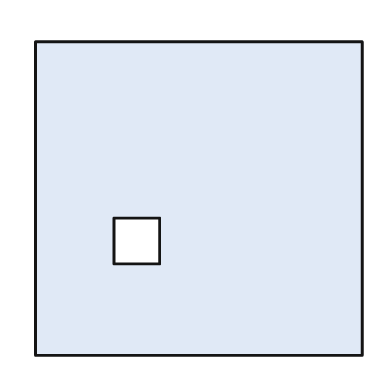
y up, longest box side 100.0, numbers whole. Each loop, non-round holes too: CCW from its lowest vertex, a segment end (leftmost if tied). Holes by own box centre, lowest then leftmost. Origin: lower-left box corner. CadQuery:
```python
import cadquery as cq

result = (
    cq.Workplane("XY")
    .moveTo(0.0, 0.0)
    .lineTo(100.0, 0.0)
    .lineTo(100.0, 96.0)
    .lineTo(0.0, 96.0)
    .close()
    .moveTo(24.0, 28.0)
    .lineTo(38.0, 28.0)
    .lineTo(38.0, 42.0)
    .lineTo(24.0, 42.0)
    .close()
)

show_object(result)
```